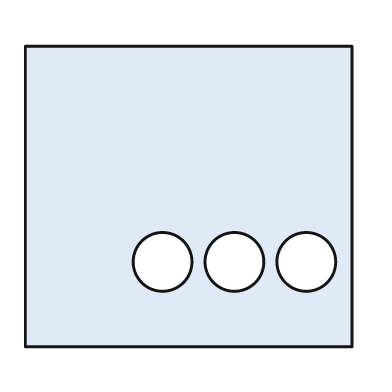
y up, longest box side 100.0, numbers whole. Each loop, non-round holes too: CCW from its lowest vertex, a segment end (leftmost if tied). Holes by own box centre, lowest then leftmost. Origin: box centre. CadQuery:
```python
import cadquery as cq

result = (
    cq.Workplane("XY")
    .moveTo(-50.0, -46.0)
    .lineTo(50.0, -46.0)
    .lineTo(50.0, 46.0)
    .lineTo(-50.0, 46.0)
    .close()
    .moveTo(-8.0, -20.0)
    .circle(9.0)
    .moveTo(14.0, -20.0)
    .circle(9.0)
    .moveTo(36.0, -20.0)
    .circle(9.0)
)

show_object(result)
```